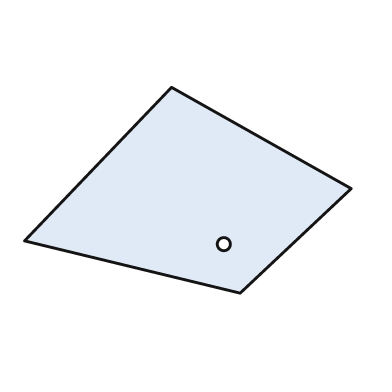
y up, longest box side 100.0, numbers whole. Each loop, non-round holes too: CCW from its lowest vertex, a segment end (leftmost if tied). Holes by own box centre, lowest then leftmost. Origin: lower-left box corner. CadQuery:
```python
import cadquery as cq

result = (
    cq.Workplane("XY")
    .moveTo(66.0, 0.0)
    .lineTo(100.0, 32.0)
    .lineTo(45.0, 63.0)
    .lineTo(0.0, 16.0)
    .close()
    .moveTo(61.0, 15.0)
    .circle(2.0)
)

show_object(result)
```